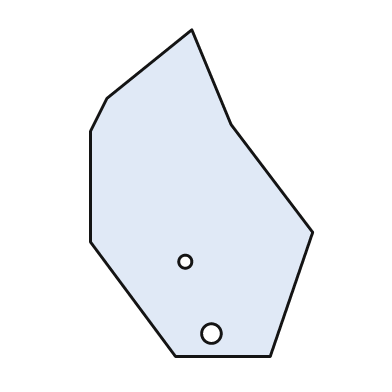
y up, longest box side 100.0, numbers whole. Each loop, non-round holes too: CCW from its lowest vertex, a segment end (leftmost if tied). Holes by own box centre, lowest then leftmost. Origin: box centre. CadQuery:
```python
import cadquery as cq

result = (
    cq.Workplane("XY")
    .moveTo(-8.0, -50.0)
    .lineTo(21.0, -50.0)
    .lineTo(34.0, -12.0)
    .lineTo(9.0, 21.0)
    .lineTo(-3.0, 50.0)
    .lineTo(-29.0, 29.0)
    .lineTo(-34.0, 19.0)
    .lineTo(-34.0, -15.0)
    .close()
    .moveTo(3.0, -43.0)
    .circle(3.0)
    .moveTo(-5.0, -21.0)
    .circle(2.0)
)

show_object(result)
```